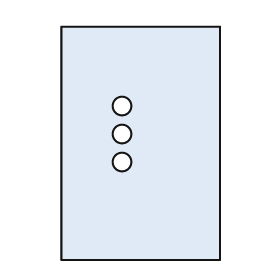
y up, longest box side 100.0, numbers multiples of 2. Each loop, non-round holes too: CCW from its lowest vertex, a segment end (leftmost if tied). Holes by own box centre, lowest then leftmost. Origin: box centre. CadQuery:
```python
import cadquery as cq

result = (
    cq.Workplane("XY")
    .moveTo(-34.0, -50.0)
    .lineTo(34.0, -50.0)
    .lineTo(34.0, 50.0)
    .lineTo(-34.0, 50.0)
    .close()
    .moveTo(-8.0, -8.0)
    .circle(4.0)
    .moveTo(-8.0, 4.0)
    .circle(4.0)
    .moveTo(-8.0, 16.0)
    .circle(4.0)
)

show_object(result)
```